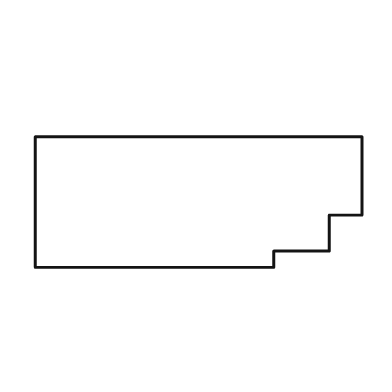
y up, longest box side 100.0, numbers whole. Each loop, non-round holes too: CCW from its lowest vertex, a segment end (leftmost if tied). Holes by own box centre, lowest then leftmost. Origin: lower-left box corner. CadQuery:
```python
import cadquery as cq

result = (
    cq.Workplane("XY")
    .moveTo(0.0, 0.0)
    .lineTo(73.0, 0.0)
    .lineTo(73.0, 5.0)
    .lineTo(90.0, 5.0)
    .lineTo(90.0, 16.0)
    .lineTo(100.0, 16.0)
    .lineTo(100.0, 40.0)
    .lineTo(0.0, 40.0)
    .close()
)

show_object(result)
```